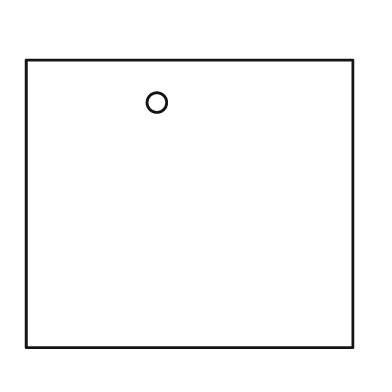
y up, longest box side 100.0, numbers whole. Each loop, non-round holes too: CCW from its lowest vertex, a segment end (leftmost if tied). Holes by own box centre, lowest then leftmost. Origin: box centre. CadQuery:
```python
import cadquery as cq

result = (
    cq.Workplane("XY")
    .moveTo(-50.0, -44.0)
    .lineTo(50.0, -44.0)
    .lineTo(50.0, 44.0)
    .lineTo(-50.0, 44.0)
    .close()
    .moveTo(-10.0, 31.0)
    .circle(3.0)
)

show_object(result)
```